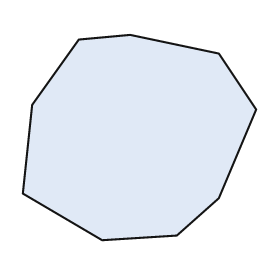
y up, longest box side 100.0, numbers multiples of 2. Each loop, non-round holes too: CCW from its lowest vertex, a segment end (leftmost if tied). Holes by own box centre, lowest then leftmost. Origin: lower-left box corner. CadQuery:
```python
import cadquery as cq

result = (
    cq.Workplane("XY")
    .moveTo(34.0, 0.0)
    .lineTo(66.0, 2.0)
    .lineTo(84.0, 18.0)
    .lineTo(100.0, 56.0)
    .lineTo(84.0, 80.0)
    .lineTo(46.0, 88.0)
    .lineTo(24.0, 86.0)
    .lineTo(4.0, 58.0)
    .lineTo(0.0, 20.0)
    .close()
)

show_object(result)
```